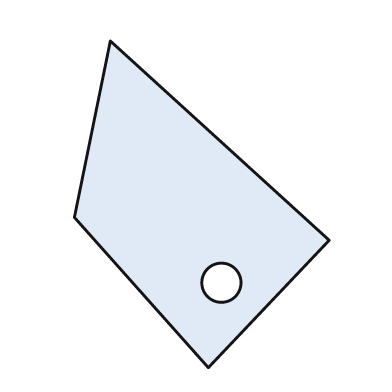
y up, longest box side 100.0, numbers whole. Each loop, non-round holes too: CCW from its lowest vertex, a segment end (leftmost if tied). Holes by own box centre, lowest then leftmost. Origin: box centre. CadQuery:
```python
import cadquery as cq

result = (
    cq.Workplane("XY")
    .moveTo(2.0, -50.0)
    .lineTo(39.0, -11.0)
    .lineTo(-28.0, 50.0)
    .lineTo(-39.0, -4.0)
    .close()
    .moveTo(6.0, -24.0)
    .circle(6.0)
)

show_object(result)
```